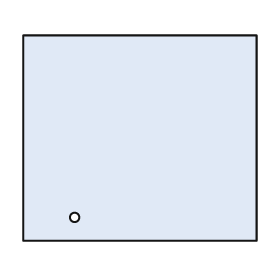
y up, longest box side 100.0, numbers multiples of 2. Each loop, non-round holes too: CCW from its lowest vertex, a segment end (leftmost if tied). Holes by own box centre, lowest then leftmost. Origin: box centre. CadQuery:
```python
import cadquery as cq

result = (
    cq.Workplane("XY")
    .moveTo(-50.0, -44.0)
    .lineTo(50.0, -44.0)
    .lineTo(50.0, 44.0)
    .lineTo(-50.0, 44.0)
    .close()
    .moveTo(-28.0, -34.0)
    .circle(2.0)
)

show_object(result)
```